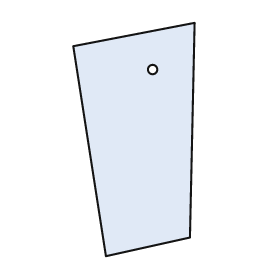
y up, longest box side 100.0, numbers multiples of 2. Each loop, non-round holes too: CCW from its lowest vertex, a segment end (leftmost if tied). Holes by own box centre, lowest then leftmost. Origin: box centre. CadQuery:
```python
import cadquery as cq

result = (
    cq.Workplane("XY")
    .moveTo(-12.0, -50.0)
    .lineTo(24.0, -42.0)
    .lineTo(26.0, 50.0)
    .lineTo(-26.0, 40.0)
    .close()
    .moveTo(8.0, 30.0)
    .circle(2.0)
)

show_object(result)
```